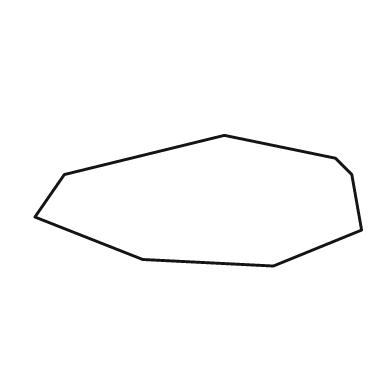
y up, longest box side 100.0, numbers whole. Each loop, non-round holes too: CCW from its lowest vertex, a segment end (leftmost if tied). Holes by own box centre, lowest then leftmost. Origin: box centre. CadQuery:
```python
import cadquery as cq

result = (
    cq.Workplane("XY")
    .moveTo(23.0, -20.0)
    .lineTo(50.0, -9.0)
    .lineTo(47.0, 8.0)
    .lineTo(42.0, 13.0)
    .lineTo(8.0, 20.0)
    .lineTo(-41.0, 8.0)
    .lineTo(-50.0, -5.0)
    .lineTo(-17.0, -18.0)
    .close()
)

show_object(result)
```